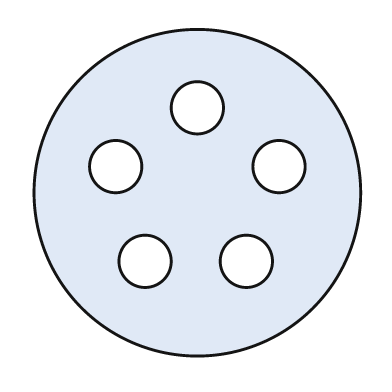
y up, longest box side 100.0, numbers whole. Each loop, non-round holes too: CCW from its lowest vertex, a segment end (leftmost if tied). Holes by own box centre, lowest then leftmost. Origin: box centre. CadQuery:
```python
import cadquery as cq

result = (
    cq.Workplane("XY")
    .moveTo(0.0, 0.0)
    .circle(50.0)
    .moveTo(-16.0, -21.0)
    .circle(8.0)
    .moveTo(15.0, -21.0)
    .circle(8.0)
    .moveTo(-25.0, 8.0)
    .circle(8.0)
    .moveTo(25.0, 8.0)
    .circle(8.0)
    .moveTo(0.0, 26.0)
    .circle(8.0)
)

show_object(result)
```